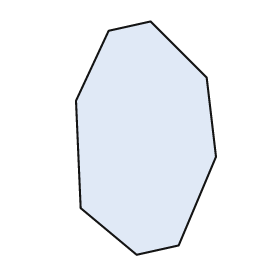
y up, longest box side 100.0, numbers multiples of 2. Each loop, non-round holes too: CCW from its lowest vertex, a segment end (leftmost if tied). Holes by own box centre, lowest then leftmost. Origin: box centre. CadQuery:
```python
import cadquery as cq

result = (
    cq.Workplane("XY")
    .moveTo(-4.0, -50.0)
    .lineTo(14.0, -46.0)
    .lineTo(30.0, -8.0)
    .lineTo(26.0, 26.0)
    .lineTo(2.0, 50.0)
    .lineTo(-16.0, 46.0)
    .lineTo(-30.0, 16.0)
    .lineTo(-28.0, -30.0)
    .close()
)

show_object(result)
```